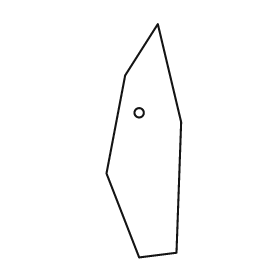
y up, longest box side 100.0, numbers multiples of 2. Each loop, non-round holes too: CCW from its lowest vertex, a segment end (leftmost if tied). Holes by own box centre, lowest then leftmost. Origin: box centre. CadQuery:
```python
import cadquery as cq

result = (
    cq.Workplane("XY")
    .moveTo(-2.0, -50.0)
    .lineTo(14.0, -48.0)
    .lineTo(16.0, 8.0)
    .lineTo(6.0, 50.0)
    .lineTo(-8.0, 28.0)
    .lineTo(-16.0, -14.0)
    .close()
    .moveTo(-2.0, 12.0)
    .circle(2.0)
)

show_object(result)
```